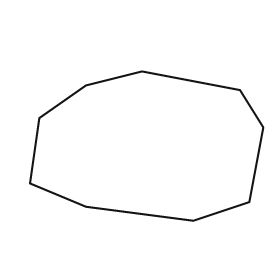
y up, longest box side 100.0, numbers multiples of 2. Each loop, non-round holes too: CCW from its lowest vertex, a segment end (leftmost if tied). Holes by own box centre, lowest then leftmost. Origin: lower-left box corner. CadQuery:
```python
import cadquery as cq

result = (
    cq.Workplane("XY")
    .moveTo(70.0, 0.0)
    .lineTo(94.0, 8.0)
    .lineTo(100.0, 40.0)
    .lineTo(90.0, 56.0)
    .lineTo(48.0, 64.0)
    .lineTo(24.0, 58.0)
    .lineTo(4.0, 44.0)
    .lineTo(0.0, 16.0)
    .lineTo(24.0, 6.0)
    .close()
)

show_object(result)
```